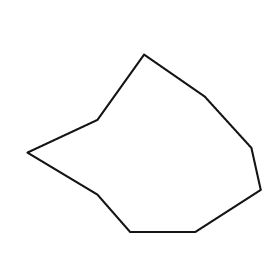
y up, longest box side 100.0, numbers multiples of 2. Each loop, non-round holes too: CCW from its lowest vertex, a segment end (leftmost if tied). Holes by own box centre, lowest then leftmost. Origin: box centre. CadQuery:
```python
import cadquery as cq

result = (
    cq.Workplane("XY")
    .moveTo(-6.0, -38.0)
    .lineTo(22.0, -38.0)
    .lineTo(50.0, -20.0)
    .lineTo(46.0, -2.0)
    .lineTo(26.0, 20.0)
    .lineTo(0.0, 38.0)
    .lineTo(-20.0, 10.0)
    .lineTo(-50.0, -4.0)
    .lineTo(-20.0, -22.0)
    .close()
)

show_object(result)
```